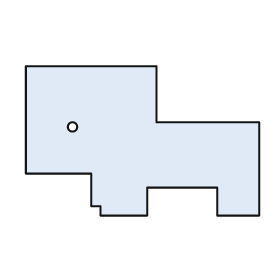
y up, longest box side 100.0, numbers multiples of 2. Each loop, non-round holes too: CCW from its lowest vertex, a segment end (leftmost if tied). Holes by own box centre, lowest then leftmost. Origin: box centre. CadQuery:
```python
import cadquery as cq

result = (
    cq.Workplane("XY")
    .moveTo(-18.0, -32.0)
    .lineTo(2.0, -32.0)
    .lineTo(2.0, -20.0)
    .lineTo(32.0, -20.0)
    .lineTo(32.0, -32.0)
    .lineTo(50.0, -32.0)
    .lineTo(50.0, 8.0)
    .lineTo(6.0, 8.0)
    .lineTo(6.0, 32.0)
    .lineTo(-50.0, 32.0)
    .lineTo(-50.0, -14.0)
    .lineTo(-22.0, -14.0)
    .lineTo(-22.0, -28.0)
    .lineTo(-18.0, -28.0)
    .close()
    .moveTo(-30.0, 6.0)
    .circle(2.0)
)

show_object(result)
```